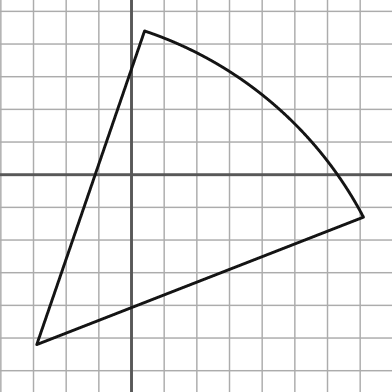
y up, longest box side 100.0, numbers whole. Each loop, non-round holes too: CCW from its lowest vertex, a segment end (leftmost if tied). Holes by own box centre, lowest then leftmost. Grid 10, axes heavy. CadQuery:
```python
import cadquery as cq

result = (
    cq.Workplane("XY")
    .moveTo(-29.0, -52.0)
    .lineTo(71.0, -13.0)
    .threePointArc((43.0, 22.0), (4.0, 44.0))
    .close()
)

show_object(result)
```